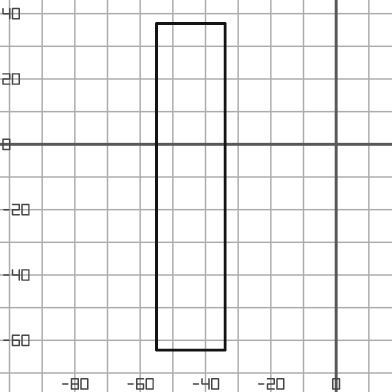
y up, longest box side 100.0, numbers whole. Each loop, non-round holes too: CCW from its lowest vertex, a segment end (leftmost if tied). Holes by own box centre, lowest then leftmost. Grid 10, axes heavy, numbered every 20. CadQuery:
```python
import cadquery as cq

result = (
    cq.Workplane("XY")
    .moveTo(-55.0, -63.0)
    .lineTo(-34.0, -63.0)
    .lineTo(-34.0, 37.0)
    .lineTo(-55.0, 37.0)
    .close()
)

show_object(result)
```